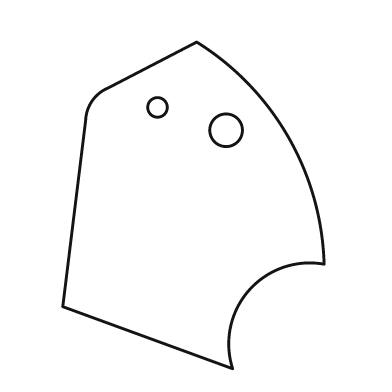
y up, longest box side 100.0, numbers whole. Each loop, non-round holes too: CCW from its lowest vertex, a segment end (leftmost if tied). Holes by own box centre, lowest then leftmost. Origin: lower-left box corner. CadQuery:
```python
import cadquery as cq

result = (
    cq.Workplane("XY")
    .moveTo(52.0, 0.0)
    .threePointArc((57.0, 24.0), (80.0, 32.0))
    .threePointArc((69.0, 71.0), (41.0, 100.0))
    .lineTo(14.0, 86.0)
    .threePointArc((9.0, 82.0), (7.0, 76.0))
    .lineTo(0.0, 19.0)
    .close()
    .moveTo(50.0, 73.0)
    .circle(5.0)
    .moveTo(29.0, 80.0)
    .circle(3.0)
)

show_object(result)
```